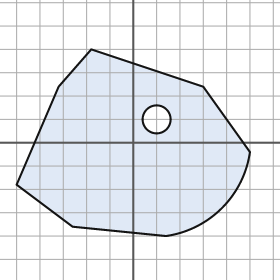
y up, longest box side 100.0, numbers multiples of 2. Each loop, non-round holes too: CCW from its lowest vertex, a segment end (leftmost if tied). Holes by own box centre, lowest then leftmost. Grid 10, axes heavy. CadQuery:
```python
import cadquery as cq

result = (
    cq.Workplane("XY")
    .moveTo(14.0, -40.0)
    .threePointArc((38.0, -28.0), (50.0, -4.0))
    .lineTo(30.0, 24.0)
    .lineTo(-18.0, 40.0)
    .lineTo(-32.0, 24.0)
    .lineTo(-50.0, -18.0)
    .lineTo(-26.0, -36.0)
    .close()
    .moveTo(10.0, 10.0)
    .circle(6.0)
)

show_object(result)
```